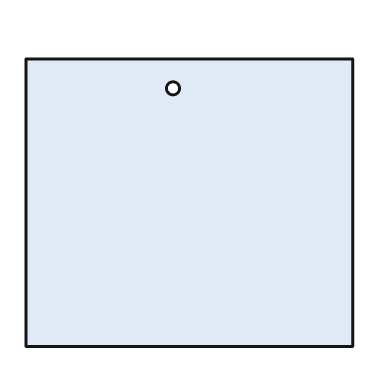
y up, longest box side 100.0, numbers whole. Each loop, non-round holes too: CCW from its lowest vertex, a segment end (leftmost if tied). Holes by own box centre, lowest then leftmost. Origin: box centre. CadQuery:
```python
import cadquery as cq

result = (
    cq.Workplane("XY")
    .moveTo(-50.0, -44.0)
    .lineTo(50.0, -44.0)
    .lineTo(50.0, 44.0)
    .lineTo(-50.0, 44.0)
    .close()
    .moveTo(-5.0, 35.0)
    .circle(2.0)
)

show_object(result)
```